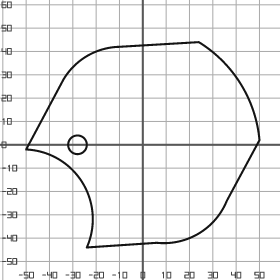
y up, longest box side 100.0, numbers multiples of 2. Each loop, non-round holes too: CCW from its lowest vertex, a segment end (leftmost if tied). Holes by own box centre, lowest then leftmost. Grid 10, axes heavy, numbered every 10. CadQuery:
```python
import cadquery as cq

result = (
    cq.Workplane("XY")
    .moveTo(-24.0, -44.0)
    .lineTo(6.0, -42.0)
    .threePointArc((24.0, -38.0), (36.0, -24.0))
    .lineTo(50.0, 2.0)
    .threePointArc((42.0, 26.0), (24.0, 44.0))
    .lineTo(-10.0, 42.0)
    .threePointArc((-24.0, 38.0), (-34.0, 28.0))
    .lineTo(-50.0, -2.0)
    .threePointArc((-26.0, -16.0), (-24.0, -44.0))
    .close()
    .moveTo(-28.0, 0.0)
    .circle(4.0)
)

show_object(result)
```